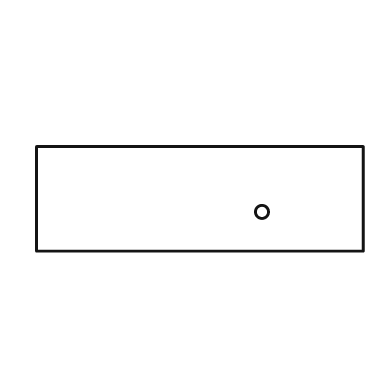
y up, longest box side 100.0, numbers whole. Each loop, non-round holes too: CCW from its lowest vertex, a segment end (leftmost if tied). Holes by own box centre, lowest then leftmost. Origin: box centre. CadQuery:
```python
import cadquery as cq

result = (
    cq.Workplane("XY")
    .moveTo(-50.0, -16.0)
    .lineTo(50.0, -16.0)
    .lineTo(50.0, 16.0)
    .lineTo(-50.0, 16.0)
    .close()
    .moveTo(19.0, -4.0)
    .circle(2.0)
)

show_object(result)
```